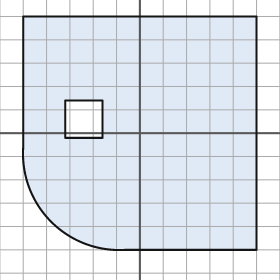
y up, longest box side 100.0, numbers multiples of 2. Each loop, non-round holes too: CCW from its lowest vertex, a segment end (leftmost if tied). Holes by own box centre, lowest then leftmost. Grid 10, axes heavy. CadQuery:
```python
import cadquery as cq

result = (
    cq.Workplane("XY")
    .moveTo(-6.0, -50.0)
    .lineTo(50.0, -50.0)
    .lineTo(50.0, 50.0)
    .lineTo(-50.0, 50.0)
    .lineTo(-50.0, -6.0)
    .threePointArc((-38.0, -38.0), (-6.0, -50.0))
    .close()
    .moveTo(-32.0, -2.0)
    .lineTo(-16.0, -2.0)
    .lineTo(-16.0, 14.0)
    .lineTo(-32.0, 14.0)
    .close()
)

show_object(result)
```